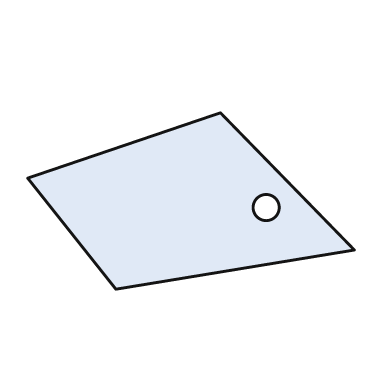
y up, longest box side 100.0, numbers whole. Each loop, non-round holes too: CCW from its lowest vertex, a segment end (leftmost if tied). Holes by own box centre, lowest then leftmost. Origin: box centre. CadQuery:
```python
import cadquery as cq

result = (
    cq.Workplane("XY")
    .moveTo(-23.0, -27.0)
    .lineTo(50.0, -15.0)
    .lineTo(9.0, 27.0)
    .lineTo(-50.0, 7.0)
    .close()
    .moveTo(23.0, -2.0)
    .circle(4.0)
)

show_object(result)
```